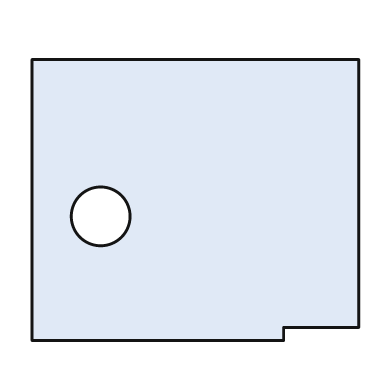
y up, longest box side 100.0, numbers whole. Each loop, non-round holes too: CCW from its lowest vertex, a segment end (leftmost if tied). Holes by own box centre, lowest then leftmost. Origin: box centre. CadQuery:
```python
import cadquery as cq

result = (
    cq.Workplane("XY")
    .moveTo(-50.0, -43.0)
    .lineTo(27.0, -43.0)
    .lineTo(27.0, -39.0)
    .lineTo(50.0, -39.0)
    .lineTo(50.0, 43.0)
    .lineTo(-50.0, 43.0)
    .close()
    .moveTo(-29.0, -5.0)
    .circle(9.0)
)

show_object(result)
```